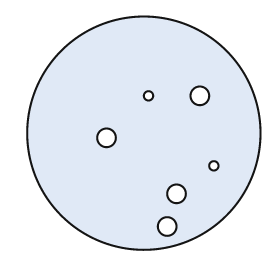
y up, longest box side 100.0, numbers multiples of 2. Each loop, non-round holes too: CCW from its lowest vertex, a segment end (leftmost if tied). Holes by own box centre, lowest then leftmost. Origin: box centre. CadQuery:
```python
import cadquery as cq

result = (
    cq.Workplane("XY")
    .moveTo(0.0, 0.0)
    .circle(50.0)
    .moveTo(10.0, -40.0)
    .circle(4.0)
    .moveTo(14.0, -26.0)
    .circle(4.0)
    .moveTo(30.0, -14.0)
    .circle(2.0)
    .moveTo(-16.0, -2.0)
    .circle(4.0)
    .moveTo(2.0, 16.0)
    .circle(2.0)
    .moveTo(24.0, 16.0)
    .circle(4.0)
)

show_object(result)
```